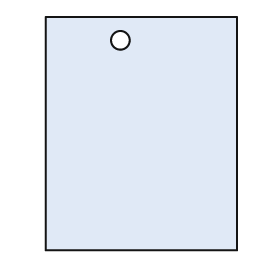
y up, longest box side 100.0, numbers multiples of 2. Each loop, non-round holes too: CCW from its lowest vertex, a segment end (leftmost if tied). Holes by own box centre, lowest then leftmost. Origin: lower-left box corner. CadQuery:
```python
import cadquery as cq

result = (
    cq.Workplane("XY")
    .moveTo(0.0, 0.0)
    .lineTo(82.0, 0.0)
    .lineTo(82.0, 100.0)
    .lineTo(0.0, 100.0)
    .close()
    .moveTo(32.0, 90.0)
    .circle(4.0)
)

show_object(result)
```